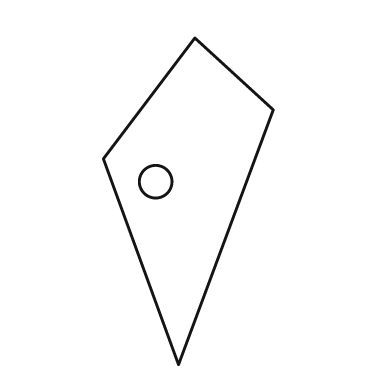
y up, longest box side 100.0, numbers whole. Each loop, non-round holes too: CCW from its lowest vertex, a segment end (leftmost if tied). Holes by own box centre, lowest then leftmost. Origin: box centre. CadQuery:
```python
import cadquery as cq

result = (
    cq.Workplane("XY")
    .moveTo(-3.0, -50.0)
    .lineTo(26.0, 28.0)
    .lineTo(2.0, 50.0)
    .lineTo(-26.0, 13.0)
    .close()
    .moveTo(-10.0, 6.0)
    .circle(5.0)
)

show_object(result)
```